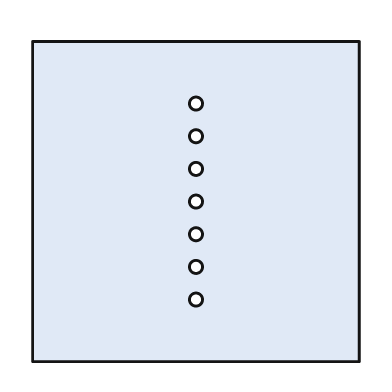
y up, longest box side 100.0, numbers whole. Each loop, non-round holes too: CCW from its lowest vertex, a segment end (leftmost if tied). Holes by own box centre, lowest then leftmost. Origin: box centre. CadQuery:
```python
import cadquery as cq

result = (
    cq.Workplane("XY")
    .moveTo(-50.0, -49.0)
    .lineTo(50.0, -49.0)
    .lineTo(50.0, 49.0)
    .lineTo(-50.0, 49.0)
    .close()
    .moveTo(0.0, -30.0)
    .circle(2.0)
    .moveTo(0.0, -20.0)
    .circle(2.0)
    .moveTo(0.0, -10.0)
    .circle(2.0)
    .moveTo(0.0, 0.0)
    .circle(2.0)
    .moveTo(0.0, 10.0)
    .circle(2.0)
    .moveTo(0.0, 20.0)
    .circle(2.0)
    .moveTo(0.0, 30.0)
    .circle(2.0)
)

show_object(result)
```